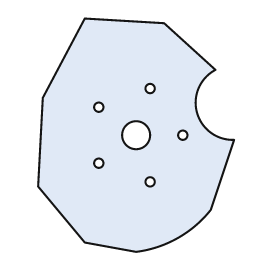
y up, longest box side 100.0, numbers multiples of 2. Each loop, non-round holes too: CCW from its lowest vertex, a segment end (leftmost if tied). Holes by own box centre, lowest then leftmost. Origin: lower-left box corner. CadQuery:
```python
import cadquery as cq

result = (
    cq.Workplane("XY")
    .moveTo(42.0, 0.0)
    .threePointArc((60.0, 6.0), (74.0, 18.0))
    .lineTo(84.0, 48.0)
    .threePointArc((68.0, 60.0), (76.0, 78.0))
    .lineTo(54.0, 98.0)
    .lineTo(20.0, 100.0)
    .lineTo(2.0, 66.0)
    .lineTo(0.0, 28.0)
    .lineTo(20.0, 4.0)
    .close()
    .moveTo(48.0, 30.0)
    .circle(2.0)
    .moveTo(26.0, 38.0)
    .circle(2.0)
    .moveTo(42.0, 50.0)
    .circle(6.0)
    .moveTo(62.0, 50.0)
    .circle(2.0)
    .moveTo(26.0, 62.0)
    .circle(2.0)
    .moveTo(48.0, 70.0)
    .circle(2.0)
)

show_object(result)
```